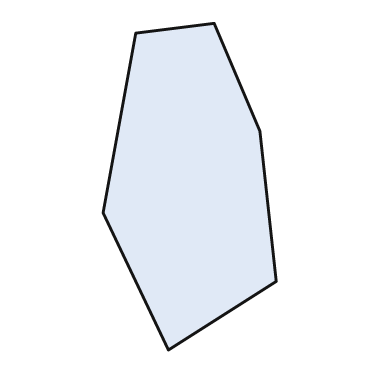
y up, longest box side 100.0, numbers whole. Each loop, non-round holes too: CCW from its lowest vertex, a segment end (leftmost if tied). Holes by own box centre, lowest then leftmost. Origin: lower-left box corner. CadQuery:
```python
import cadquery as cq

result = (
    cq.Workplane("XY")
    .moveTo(20.0, 0.0)
    .lineTo(53.0, 21.0)
    .lineTo(48.0, 67.0)
    .lineTo(34.0, 100.0)
    .lineTo(10.0, 97.0)
    .lineTo(0.0, 42.0)
    .close()
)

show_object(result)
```